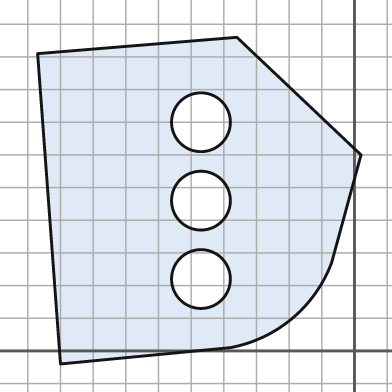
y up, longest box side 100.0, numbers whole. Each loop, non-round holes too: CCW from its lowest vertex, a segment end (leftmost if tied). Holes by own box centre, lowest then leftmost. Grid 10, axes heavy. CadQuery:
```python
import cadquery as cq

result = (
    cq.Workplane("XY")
    .moveTo(-90.0, -4.0)
    .lineTo(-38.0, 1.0)
    .threePointArc((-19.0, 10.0), (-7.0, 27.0))
    .lineTo(2.0, 60.0)
    .lineTo(-36.0, 96.0)
    .lineTo(-97.0, 91.0)
    .close()
    .moveTo(-47.0, 22.0)
    .circle(9.0)
    .moveTo(-47.0, 46.0)
    .circle(9.0)
    .moveTo(-47.0, 70.0)
    .circle(9.0)
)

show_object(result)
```